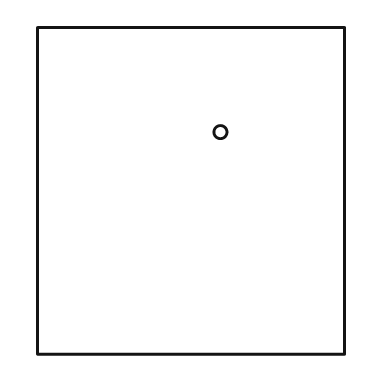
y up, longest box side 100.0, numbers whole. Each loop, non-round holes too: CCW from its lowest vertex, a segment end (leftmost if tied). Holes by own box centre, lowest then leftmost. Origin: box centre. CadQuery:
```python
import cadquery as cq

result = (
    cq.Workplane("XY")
    .moveTo(-47.0, -50.0)
    .lineTo(47.0, -50.0)
    .lineTo(47.0, 50.0)
    .lineTo(-47.0, 50.0)
    .close()
    .moveTo(9.0, 18.0)
    .circle(2.0)
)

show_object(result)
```